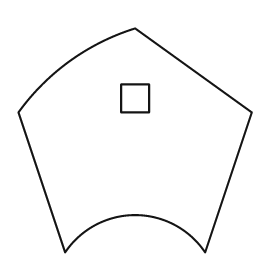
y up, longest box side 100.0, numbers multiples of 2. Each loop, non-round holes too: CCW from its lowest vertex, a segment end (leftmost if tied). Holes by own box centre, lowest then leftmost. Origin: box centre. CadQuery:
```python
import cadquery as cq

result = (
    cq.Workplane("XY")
    .moveTo(-30.0, -48.0)
    .threePointArc((0.0, -32.0), (30.0, -48.0))
    .lineTo(50.0, 12.0)
    .lineTo(0.0, 48.0)
    .threePointArc((-28.0, 34.0), (-50.0, 12.0))
    .close()
    .moveTo(-6.0, 12.0)
    .lineTo(6.0, 12.0)
    .lineTo(6.0, 24.0)
    .lineTo(-6.0, 24.0)
    .close()
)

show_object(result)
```